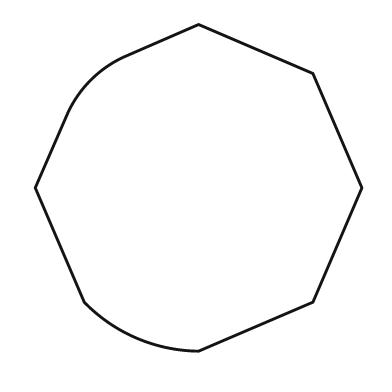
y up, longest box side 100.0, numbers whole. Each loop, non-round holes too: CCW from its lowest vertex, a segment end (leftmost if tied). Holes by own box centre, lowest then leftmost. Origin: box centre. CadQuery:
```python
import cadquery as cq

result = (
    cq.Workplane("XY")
    .moveTo(0.0, -50.0)
    .lineTo(35.0, -35.0)
    .lineTo(50.0, 0.0)
    .lineTo(35.0, 35.0)
    .lineTo(0.0, 50.0)
    .lineTo(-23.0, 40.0)
    .threePointArc((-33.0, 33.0), (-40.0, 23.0))
    .lineTo(-50.0, 0.0)
    .lineTo(-35.0, -35.0)
    .threePointArc((-19.0, -46.0), (0.0, -50.0))
    .close()
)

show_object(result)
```